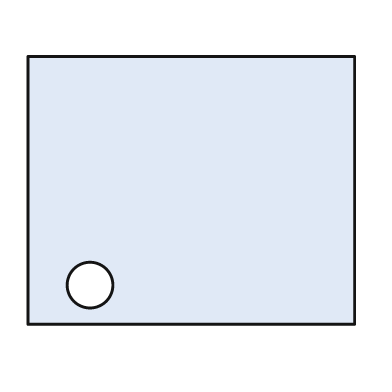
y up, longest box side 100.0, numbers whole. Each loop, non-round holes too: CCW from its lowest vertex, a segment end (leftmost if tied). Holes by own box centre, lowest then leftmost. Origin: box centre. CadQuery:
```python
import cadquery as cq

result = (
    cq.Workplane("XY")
    .moveTo(-50.0, -41.0)
    .lineTo(50.0, -41.0)
    .lineTo(50.0, 41.0)
    .lineTo(-50.0, 41.0)
    .close()
    .moveTo(-31.0, -29.0)
    .circle(7.0)
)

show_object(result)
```